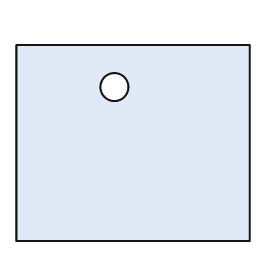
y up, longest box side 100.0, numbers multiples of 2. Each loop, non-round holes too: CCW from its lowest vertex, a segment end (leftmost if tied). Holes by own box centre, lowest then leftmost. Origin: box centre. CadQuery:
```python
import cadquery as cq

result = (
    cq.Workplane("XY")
    .moveTo(-50.0, -42.0)
    .lineTo(50.0, -42.0)
    .lineTo(50.0, 42.0)
    .lineTo(-50.0, 42.0)
    .close()
    .moveTo(-8.0, 24.0)
    .circle(6.0)
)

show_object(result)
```